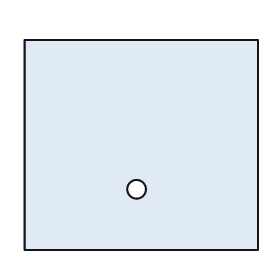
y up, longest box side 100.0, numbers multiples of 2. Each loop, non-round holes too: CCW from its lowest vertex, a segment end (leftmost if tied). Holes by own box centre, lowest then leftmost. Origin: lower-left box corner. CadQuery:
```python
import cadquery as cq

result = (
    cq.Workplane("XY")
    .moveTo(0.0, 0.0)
    .lineTo(100.0, 0.0)
    .lineTo(100.0, 90.0)
    .lineTo(0.0, 90.0)
    .close()
    .moveTo(48.0, 26.0)
    .circle(4.0)
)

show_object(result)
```